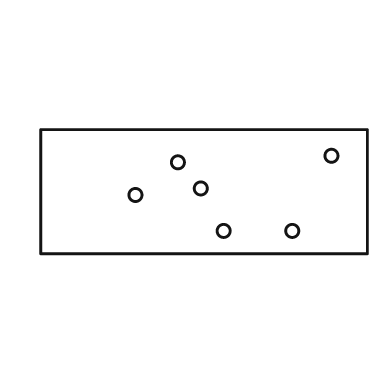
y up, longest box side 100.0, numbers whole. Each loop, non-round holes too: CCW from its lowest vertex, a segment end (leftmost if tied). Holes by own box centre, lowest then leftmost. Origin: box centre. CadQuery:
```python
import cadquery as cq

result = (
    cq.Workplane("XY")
    .moveTo(-50.0, -19.0)
    .lineTo(50.0, -19.0)
    .lineTo(50.0, 19.0)
    .lineTo(-50.0, 19.0)
    .close()
    .moveTo(6.0, -12.0)
    .circle(2.0)
    .moveTo(27.0, -12.0)
    .circle(2.0)
    .moveTo(-21.0, -1.0)
    .circle(2.0)
    .moveTo(-1.0, 1.0)
    .circle(2.0)
    .moveTo(-8.0, 9.0)
    .circle(2.0)
    .moveTo(39.0, 11.0)
    .circle(2.0)
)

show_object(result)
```